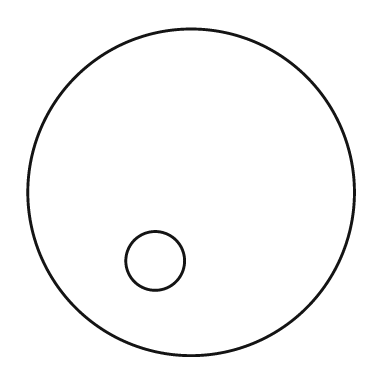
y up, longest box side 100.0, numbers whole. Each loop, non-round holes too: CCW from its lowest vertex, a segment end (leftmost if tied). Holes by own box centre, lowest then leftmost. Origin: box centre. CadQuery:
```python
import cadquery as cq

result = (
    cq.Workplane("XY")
    .moveTo(0.0, 0.0)
    .circle(50.0)
    .moveTo(-11.0, -21.0)
    .circle(9.0)
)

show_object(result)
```